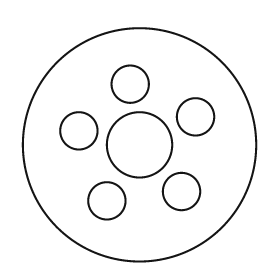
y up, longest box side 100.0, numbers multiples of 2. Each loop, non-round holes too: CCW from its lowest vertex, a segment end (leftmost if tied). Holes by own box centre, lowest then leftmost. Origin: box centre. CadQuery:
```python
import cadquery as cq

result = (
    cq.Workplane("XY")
    .moveTo(0.0, 0.0)
    .circle(50.0)
    .moveTo(-14.0, -24.0)
    .circle(8.0)
    .moveTo(18.0, -20.0)
    .circle(8.0)
    .moveTo(0.0, 0.0)
    .circle(14.0)
    .moveTo(-26.0, 6.0)
    .circle(8.0)
    .moveTo(24.0, 12.0)
    .circle(8.0)
    .moveTo(-4.0, 26.0)
    .circle(8.0)
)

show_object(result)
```